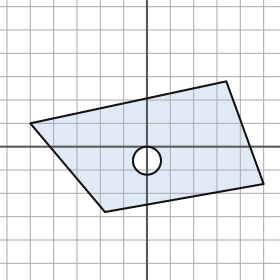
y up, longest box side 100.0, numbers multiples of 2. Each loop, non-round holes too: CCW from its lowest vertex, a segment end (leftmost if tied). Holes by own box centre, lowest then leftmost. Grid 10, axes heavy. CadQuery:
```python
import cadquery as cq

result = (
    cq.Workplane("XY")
    .moveTo(-18.0, -28.0)
    .lineTo(50.0, -16.0)
    .lineTo(34.0, 28.0)
    .lineTo(-50.0, 10.0)
    .close()
    .moveTo(0.0, -6.0)
    .circle(6.0)
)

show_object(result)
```